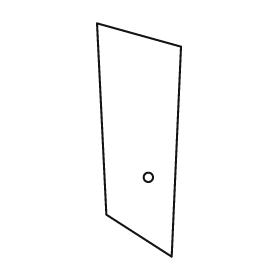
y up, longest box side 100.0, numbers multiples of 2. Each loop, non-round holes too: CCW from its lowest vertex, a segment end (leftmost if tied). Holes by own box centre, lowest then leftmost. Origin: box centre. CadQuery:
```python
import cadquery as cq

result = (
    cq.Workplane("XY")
    .moveTo(14.0, -50.0)
    .lineTo(18.0, 40.0)
    .lineTo(-18.0, 50.0)
    .lineTo(-14.0, -32.0)
    .close()
    .moveTo(4.0, -16.0)
    .circle(2.0)
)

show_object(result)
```